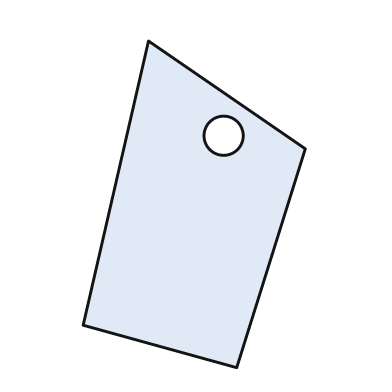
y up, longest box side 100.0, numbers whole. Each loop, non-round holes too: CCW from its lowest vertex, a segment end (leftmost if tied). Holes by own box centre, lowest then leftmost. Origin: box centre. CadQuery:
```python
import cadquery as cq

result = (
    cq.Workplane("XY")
    .moveTo(13.0, -50.0)
    .lineTo(34.0, 17.0)
    .lineTo(-14.0, 50.0)
    .lineTo(-34.0, -37.0)
    .close()
    .moveTo(9.0, 21.0)
    .circle(6.0)
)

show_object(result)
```